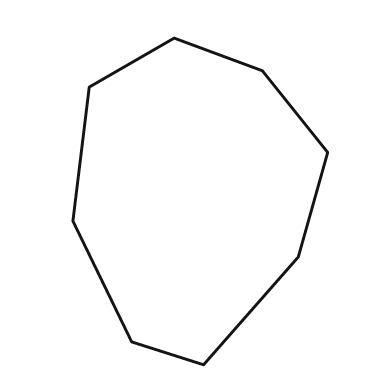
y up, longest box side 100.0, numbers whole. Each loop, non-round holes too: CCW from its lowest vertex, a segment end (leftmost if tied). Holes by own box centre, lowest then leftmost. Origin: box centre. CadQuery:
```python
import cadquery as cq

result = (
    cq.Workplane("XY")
    .moveTo(1.0, -50.0)
    .lineTo(30.0, -17.0)
    .lineTo(39.0, 15.0)
    .lineTo(19.0, 40.0)
    .lineTo(-8.0, 50.0)
    .lineTo(-34.0, 35.0)
    .lineTo(-39.0, -6.0)
    .lineTo(-21.0, -43.0)
    .close()
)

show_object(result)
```